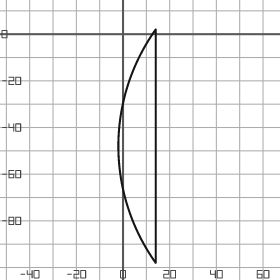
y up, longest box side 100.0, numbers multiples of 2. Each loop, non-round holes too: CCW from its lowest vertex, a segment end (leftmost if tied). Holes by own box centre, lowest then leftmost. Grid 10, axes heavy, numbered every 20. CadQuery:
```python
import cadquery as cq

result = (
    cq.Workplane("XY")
    .moveTo(14.0, -98.0)
    .lineTo(14.0, 2.0)
    .threePointArc((-2.0, -48.0), (14.0, -98.0))
    .close()
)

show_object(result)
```